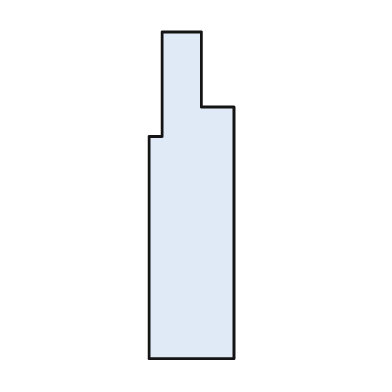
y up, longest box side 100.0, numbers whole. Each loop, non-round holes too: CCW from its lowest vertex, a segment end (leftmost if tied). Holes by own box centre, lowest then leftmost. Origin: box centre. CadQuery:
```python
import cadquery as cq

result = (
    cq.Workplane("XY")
    .moveTo(-13.0, -50.0)
    .lineTo(13.0, -50.0)
    .lineTo(13.0, 27.0)
    .lineTo(3.0, 27.0)
    .lineTo(3.0, 50.0)
    .lineTo(-9.0, 50.0)
    .lineTo(-9.0, 18.0)
    .lineTo(-13.0, 18.0)
    .close()
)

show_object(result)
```